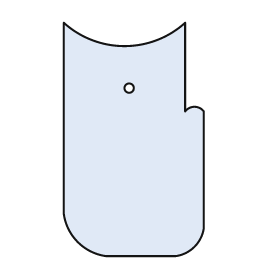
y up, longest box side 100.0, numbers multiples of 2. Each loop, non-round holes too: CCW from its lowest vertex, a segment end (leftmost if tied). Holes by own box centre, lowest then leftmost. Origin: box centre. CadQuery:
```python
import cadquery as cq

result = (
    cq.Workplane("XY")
    .moveTo(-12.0, -50.0)
    .lineTo(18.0, -50.0)
    .threePointArc((26.0, -46.0), (30.0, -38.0))
    .lineTo(30.0, 12.0)
    .threePointArc((26.0, 14.0), (22.0, 12.0))
    .lineTo(22.0, 50.0)
    .threePointArc((-4.0, 40.0), (-30.0, 50.0))
    .lineTo(-30.0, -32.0)
    .threePointArc((-24.0, -44.0), (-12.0, -50.0))
    .close()
    .moveTo(-2.0, 22.0)
    .circle(2.0)
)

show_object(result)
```